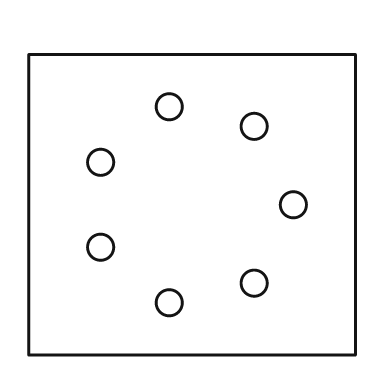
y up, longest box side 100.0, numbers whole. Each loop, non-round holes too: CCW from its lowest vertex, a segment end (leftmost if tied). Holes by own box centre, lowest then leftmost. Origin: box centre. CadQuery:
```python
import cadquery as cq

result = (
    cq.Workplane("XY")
    .moveTo(-50.0, -46.0)
    .lineTo(50.0, -46.0)
    .lineTo(50.0, 46.0)
    .lineTo(-50.0, 46.0)
    .close()
    .moveTo(-7.0, -30.0)
    .circle(4.0)
    .moveTo(19.0, -24.0)
    .circle(4.0)
    .moveTo(-28.0, -13.0)
    .circle(4.0)
    .moveTo(31.0, 0.0)
    .circle(4.0)
    .moveTo(-28.0, 13.0)
    .circle(4.0)
    .moveTo(19.0, 24.0)
    .circle(4.0)
    .moveTo(-7.0, 30.0)
    .circle(4.0)
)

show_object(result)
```